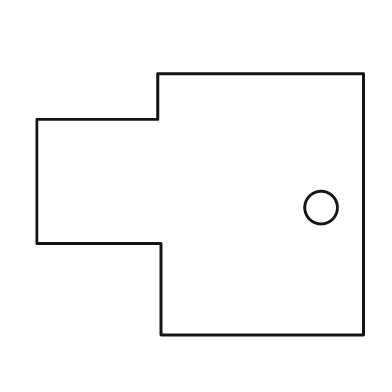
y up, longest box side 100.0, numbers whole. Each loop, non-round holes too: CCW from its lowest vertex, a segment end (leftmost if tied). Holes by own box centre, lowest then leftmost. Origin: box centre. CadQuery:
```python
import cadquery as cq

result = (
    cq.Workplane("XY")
    .moveTo(-12.0, -40.0)
    .lineTo(50.0, -40.0)
    .lineTo(50.0, 40.0)
    .lineTo(-13.0, 40.0)
    .lineTo(-13.0, 26.0)
    .lineTo(-50.0, 26.0)
    .lineTo(-50.0, -12.0)
    .lineTo(-12.0, -12.0)
    .close()
    .moveTo(37.0, -1.0)
    .circle(5.0)
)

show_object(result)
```